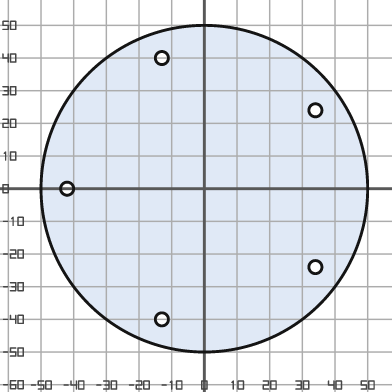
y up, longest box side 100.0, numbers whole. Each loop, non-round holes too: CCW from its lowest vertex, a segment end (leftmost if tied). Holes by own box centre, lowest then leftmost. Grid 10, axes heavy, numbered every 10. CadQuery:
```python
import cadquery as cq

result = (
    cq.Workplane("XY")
    .moveTo(0.0, 0.0)
    .circle(50.0)
    .moveTo(-13.0, -40.0)
    .circle(2.0)
    .moveTo(34.0, -24.0)
    .circle(2.0)
    .moveTo(-42.0, 0.0)
    .circle(2.0)
    .moveTo(34.0, 24.0)
    .circle(2.0)
    .moveTo(-13.0, 40.0)
    .circle(2.0)
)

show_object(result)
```